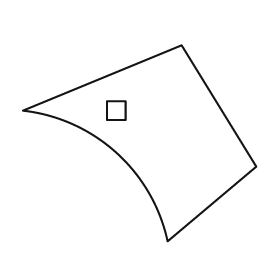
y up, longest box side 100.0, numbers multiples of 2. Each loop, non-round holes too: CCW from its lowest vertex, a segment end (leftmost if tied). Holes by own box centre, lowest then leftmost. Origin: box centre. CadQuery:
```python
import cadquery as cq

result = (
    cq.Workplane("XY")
    .moveTo(12.0, -42.0)
    .lineTo(50.0, -10.0)
    .lineTo(18.0, 42.0)
    .lineTo(-50.0, 14.0)
    .threePointArc((-10.0, -4.0), (12.0, -42.0))
    .close()
    .moveTo(-14.0, 10.0)
    .lineTo(-6.0, 10.0)
    .lineTo(-6.0, 18.0)
    .lineTo(-14.0, 18.0)
    .close()
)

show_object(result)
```